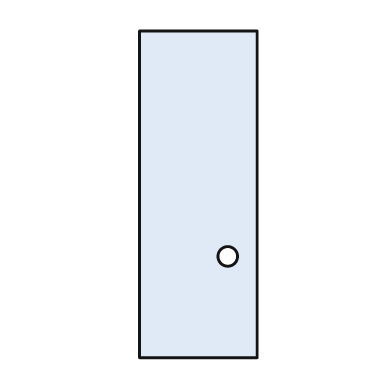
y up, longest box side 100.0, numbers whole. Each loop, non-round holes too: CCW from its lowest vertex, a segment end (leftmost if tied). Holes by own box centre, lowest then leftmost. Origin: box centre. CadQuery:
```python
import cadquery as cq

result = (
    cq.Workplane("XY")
    .moveTo(-18.0, -50.0)
    .lineTo(18.0, -50.0)
    .lineTo(18.0, 50.0)
    .lineTo(-18.0, 50.0)
    .close()
    .moveTo(9.0, -19.0)
    .circle(3.0)
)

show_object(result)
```